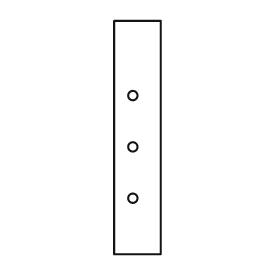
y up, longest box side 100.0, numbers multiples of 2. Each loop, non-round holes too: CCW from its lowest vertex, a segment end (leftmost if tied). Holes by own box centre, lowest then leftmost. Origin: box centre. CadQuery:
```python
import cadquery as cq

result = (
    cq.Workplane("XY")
    .moveTo(-10.0, -50.0)
    .lineTo(10.0, -50.0)
    .lineTo(10.0, 50.0)
    .lineTo(-10.0, 50.0)
    .close()
    .moveTo(-2.0, -26.0)
    .circle(2.0)
    .moveTo(-2.0, -4.0)
    .circle(2.0)
    .moveTo(-2.0, 18.0)
    .circle(2.0)
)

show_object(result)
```